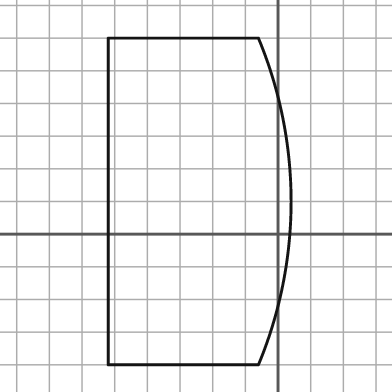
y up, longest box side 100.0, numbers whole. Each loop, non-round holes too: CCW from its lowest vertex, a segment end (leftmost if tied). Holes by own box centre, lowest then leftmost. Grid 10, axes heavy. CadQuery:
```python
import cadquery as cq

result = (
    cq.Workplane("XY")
    .moveTo(-52.0, -40.0)
    .lineTo(-6.0, -40.0)
    .threePointArc((4.0, 10.0), (-6.0, 60.0))
    .lineTo(-52.0, 60.0)
    .close()
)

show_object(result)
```